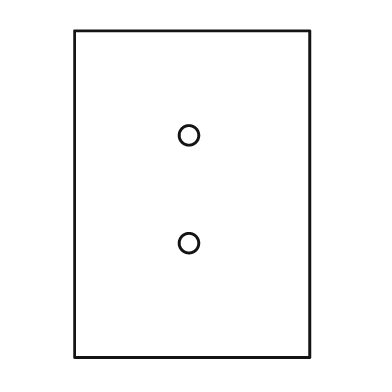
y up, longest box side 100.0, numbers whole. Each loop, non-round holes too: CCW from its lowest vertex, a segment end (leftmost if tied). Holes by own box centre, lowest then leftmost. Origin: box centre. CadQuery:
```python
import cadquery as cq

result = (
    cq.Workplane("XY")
    .moveTo(-36.0, -50.0)
    .lineTo(36.0, -50.0)
    .lineTo(36.0, 50.0)
    .lineTo(-36.0, 50.0)
    .close()
    .moveTo(-1.0, -15.0)
    .circle(3.0)
    .moveTo(-1.0, 18.0)
    .circle(3.0)
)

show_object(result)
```